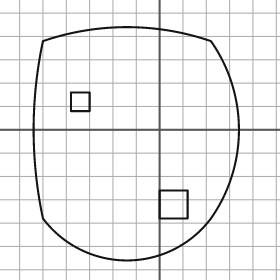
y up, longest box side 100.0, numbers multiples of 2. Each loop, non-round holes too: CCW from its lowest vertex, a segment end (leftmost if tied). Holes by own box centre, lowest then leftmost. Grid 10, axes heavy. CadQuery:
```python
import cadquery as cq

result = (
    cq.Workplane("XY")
    .moveTo(-50.0, -38.0)
    .threePointArc((-14.0, -56.0), (22.0, -38.0))
    .threePointArc((34.0, 0.0), (22.0, 38.0))
    .threePointArc((-14.0, 44.0), (-50.0, 38.0))
    .threePointArc((-54.0, 0.0), (-50.0, -38.0))
    .close()
    .moveTo(0.0, -38.0)
    .lineTo(12.0, -38.0)
    .lineTo(12.0, -26.0)
    .lineTo(0.0, -26.0)
    .close()
    .moveTo(-38.0, 8.0)
    .lineTo(-30.0, 8.0)
    .lineTo(-30.0, 16.0)
    .lineTo(-38.0, 16.0)
    .close()
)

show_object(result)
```